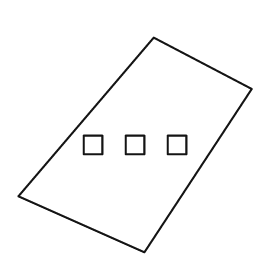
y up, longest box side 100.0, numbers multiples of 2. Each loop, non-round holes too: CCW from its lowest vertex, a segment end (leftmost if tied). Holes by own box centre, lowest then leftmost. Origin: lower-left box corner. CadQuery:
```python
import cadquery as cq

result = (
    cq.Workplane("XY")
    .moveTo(54.0, 0.0)
    .lineTo(100.0, 70.0)
    .lineTo(58.0, 92.0)
    .lineTo(0.0, 24.0)
    .close()
    .moveTo(28.0, 42.0)
    .lineTo(36.0, 42.0)
    .lineTo(36.0, 50.0)
    .lineTo(28.0, 50.0)
    .close()
    .moveTo(46.0, 42.0)
    .lineTo(54.0, 42.0)
    .lineTo(54.0, 50.0)
    .lineTo(46.0, 50.0)
    .close()
    .moveTo(64.0, 42.0)
    .lineTo(72.0, 42.0)
    .lineTo(72.0, 50.0)
    .lineTo(64.0, 50.0)
    .close()
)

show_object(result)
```